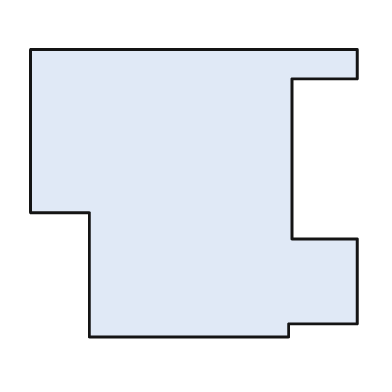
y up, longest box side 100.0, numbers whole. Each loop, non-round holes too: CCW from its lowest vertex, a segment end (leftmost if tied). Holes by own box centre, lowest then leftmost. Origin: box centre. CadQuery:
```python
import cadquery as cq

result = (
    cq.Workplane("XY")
    .moveTo(-32.0, -44.0)
    .lineTo(29.0, -44.0)
    .lineTo(29.0, -40.0)
    .lineTo(50.0, -40.0)
    .lineTo(50.0, -14.0)
    .lineTo(30.0, -14.0)
    .lineTo(30.0, 35.0)
    .lineTo(50.0, 35.0)
    .lineTo(50.0, 44.0)
    .lineTo(-50.0, 44.0)
    .lineTo(-50.0, -6.0)
    .lineTo(-32.0, -6.0)
    .close()
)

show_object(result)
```